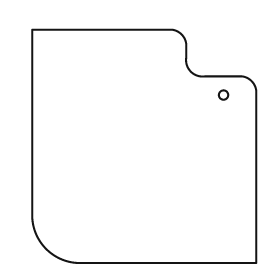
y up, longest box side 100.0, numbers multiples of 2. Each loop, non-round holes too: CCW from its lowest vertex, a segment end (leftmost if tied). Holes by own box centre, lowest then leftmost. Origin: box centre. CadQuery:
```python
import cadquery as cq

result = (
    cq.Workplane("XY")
    .moveTo(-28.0, -50.0)
    .lineTo(48.0, -50.0)
    .lineTo(48.0, 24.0)
    .threePointArc((46.0, 28.0), (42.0, 30.0))
    .lineTo(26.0, 30.0)
    .threePointArc((20.0, 32.0), (18.0, 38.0))
    .lineTo(18.0, 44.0)
    .threePointArc((16.0, 48.0), (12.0, 50.0))
    .lineTo(-48.0, 50.0)
    .lineTo(-48.0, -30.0)
    .threePointArc((-42.0, -44.0), (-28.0, -50.0))
    .close()
    .moveTo(34.0, 22.0)
    .circle(2.0)
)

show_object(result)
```